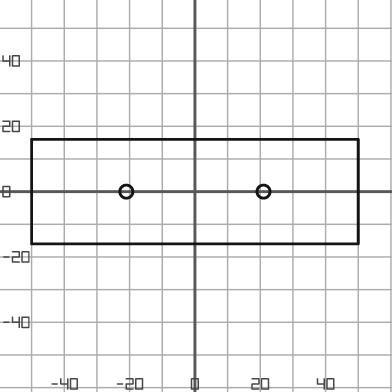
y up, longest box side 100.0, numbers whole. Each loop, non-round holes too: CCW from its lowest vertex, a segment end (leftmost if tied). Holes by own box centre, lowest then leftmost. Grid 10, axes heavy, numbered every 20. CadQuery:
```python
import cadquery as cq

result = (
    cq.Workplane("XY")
    .moveTo(-50.0, -16.0)
    .lineTo(50.0, -16.0)
    .lineTo(50.0, 16.0)
    .lineTo(-50.0, 16.0)
    .close()
    .moveTo(-21.0, 0.0)
    .circle(2.0)
    .moveTo(21.0, 0.0)
    .circle(2.0)
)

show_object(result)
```